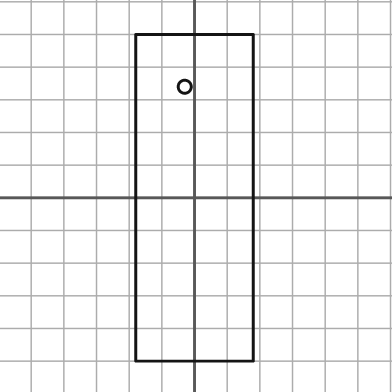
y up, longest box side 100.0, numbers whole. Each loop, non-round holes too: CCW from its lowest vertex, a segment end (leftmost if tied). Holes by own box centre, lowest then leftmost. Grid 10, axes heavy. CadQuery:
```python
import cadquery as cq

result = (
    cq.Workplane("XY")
    .moveTo(-18.0, -50.0)
    .lineTo(18.0, -50.0)
    .lineTo(18.0, 50.0)
    .lineTo(-18.0, 50.0)
    .close()
    .moveTo(-3.0, 34.0)
    .circle(2.0)
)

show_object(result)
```